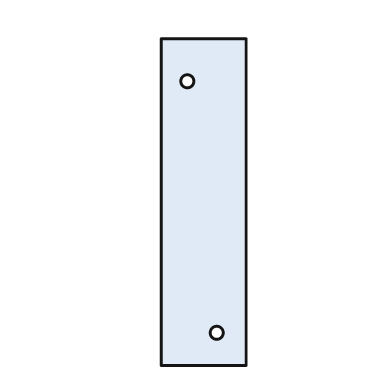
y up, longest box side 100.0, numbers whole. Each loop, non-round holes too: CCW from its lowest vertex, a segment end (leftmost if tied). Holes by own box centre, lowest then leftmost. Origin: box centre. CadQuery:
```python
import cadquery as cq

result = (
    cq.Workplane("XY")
    .moveTo(-13.0, -50.0)
    .lineTo(13.0, -50.0)
    .lineTo(13.0, 50.0)
    .lineTo(-13.0, 50.0)
    .close()
    .moveTo(4.0, -40.0)
    .circle(2.0)
    .moveTo(-5.0, 37.0)
    .circle(2.0)
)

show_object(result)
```